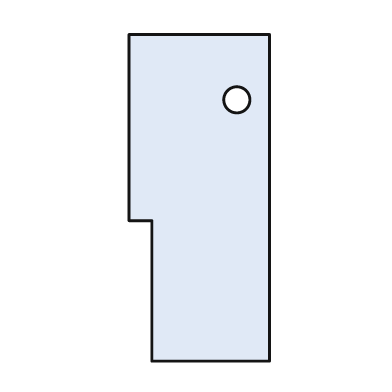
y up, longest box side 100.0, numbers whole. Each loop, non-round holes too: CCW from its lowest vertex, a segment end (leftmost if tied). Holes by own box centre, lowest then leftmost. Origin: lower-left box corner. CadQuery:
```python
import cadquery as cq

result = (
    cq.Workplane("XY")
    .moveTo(7.0, 0.0)
    .lineTo(43.0, 0.0)
    .lineTo(43.0, 100.0)
    .lineTo(0.0, 100.0)
    .lineTo(0.0, 43.0)
    .lineTo(7.0, 43.0)
    .close()
    .moveTo(33.0, 80.0)
    .circle(4.0)
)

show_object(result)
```